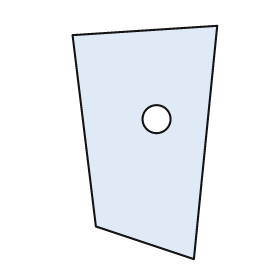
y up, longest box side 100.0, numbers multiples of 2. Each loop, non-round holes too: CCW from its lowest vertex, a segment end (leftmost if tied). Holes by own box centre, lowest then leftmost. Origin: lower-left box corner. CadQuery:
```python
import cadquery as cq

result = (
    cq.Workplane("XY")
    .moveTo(52.0, 0.0)
    .lineTo(62.0, 100.0)
    .lineTo(0.0, 96.0)
    .lineTo(10.0, 14.0)
    .close()
    .moveTo(36.0, 60.0)
    .circle(6.0)
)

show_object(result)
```